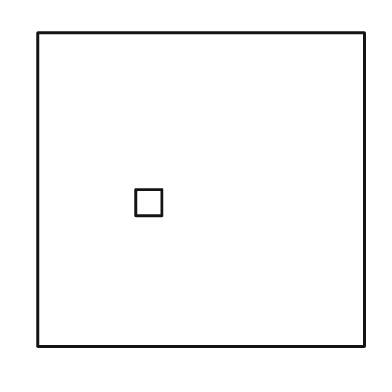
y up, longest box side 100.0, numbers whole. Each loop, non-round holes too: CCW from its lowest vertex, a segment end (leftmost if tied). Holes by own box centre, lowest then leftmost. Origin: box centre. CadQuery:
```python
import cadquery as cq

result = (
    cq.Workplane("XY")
    .moveTo(-50.0, -48.0)
    .lineTo(50.0, -48.0)
    .lineTo(50.0, 48.0)
    .lineTo(-50.0, 48.0)
    .close()
    .moveTo(-20.0, -8.0)
    .lineTo(-12.0, -8.0)
    .lineTo(-12.0, 0.0)
    .lineTo(-20.0, 0.0)
    .close()
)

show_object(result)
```